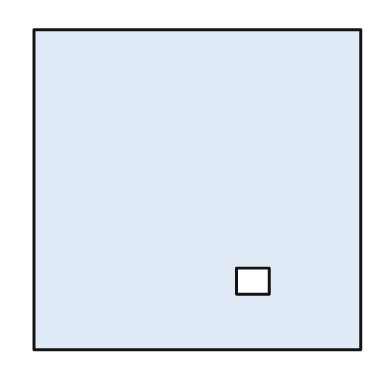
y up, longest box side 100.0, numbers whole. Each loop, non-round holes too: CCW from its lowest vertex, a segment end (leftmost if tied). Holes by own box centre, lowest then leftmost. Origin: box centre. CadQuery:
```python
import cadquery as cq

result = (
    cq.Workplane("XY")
    .moveTo(-50.0, -49.0)
    .lineTo(50.0, -49.0)
    .lineTo(50.0, 49.0)
    .lineTo(-50.0, 49.0)
    .close()
    .moveTo(12.0, -32.0)
    .lineTo(22.0, -32.0)
    .lineTo(22.0, -24.0)
    .lineTo(12.0, -24.0)
    .close()
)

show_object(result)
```